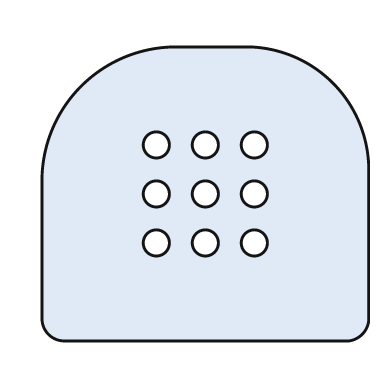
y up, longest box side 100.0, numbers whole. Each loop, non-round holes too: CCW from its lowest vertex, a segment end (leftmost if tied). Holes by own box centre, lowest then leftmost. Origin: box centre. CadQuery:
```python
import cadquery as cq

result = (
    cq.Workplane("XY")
    .moveTo(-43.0, -45.0)
    .lineTo(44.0, -45.0)
    .threePointArc((48.0, -43.0), (50.0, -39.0))
    .lineTo(50.0, 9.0)
    .threePointArc((39.0, 34.0), (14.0, 45.0))
    .lineTo(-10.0, 45.0)
    .threePointArc((-38.0, 33.0), (-50.0, 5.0))
    .lineTo(-50.0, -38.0)
    .threePointArc((-48.0, -43.0), (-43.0, -45.0))
    .close()
    .moveTo(-15.0, -15.0)
    .circle(4.0)
    .moveTo(0.0, -15.0)
    .circle(4.0)
    .moveTo(15.0, -15.0)
    .circle(4.0)
    .moveTo(-15.0, 0.0)
    .circle(4.0)
    .moveTo(0.0, 0.0)
    .circle(4.0)
    .moveTo(15.0, 0.0)
    .circle(4.0)
    .moveTo(-15.0, 15.0)
    .circle(4.0)
    .moveTo(0.0, 15.0)
    .circle(4.0)
    .moveTo(15.0, 15.0)
    .circle(4.0)
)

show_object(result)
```